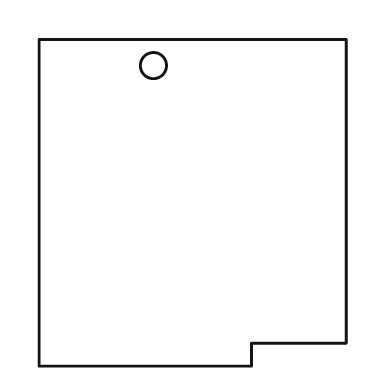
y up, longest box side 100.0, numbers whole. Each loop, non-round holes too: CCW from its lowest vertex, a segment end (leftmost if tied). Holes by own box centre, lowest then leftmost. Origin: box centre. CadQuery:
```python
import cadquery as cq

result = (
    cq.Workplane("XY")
    .moveTo(-47.0, -50.0)
    .lineTo(18.0, -50.0)
    .lineTo(18.0, -43.0)
    .lineTo(47.0, -43.0)
    .lineTo(47.0, 50.0)
    .lineTo(-47.0, 50.0)
    .close()
    .moveTo(-12.0, 42.0)
    .circle(4.0)
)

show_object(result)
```